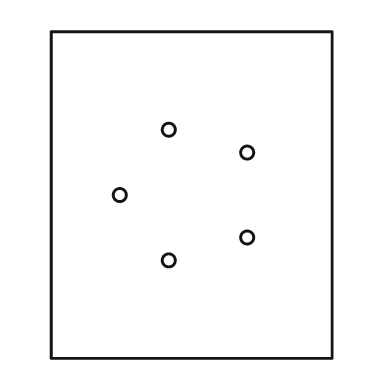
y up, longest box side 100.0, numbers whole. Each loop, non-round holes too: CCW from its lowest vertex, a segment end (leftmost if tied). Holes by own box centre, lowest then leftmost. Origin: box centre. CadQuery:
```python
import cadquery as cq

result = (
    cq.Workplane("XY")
    .moveTo(-43.0, -50.0)
    .lineTo(43.0, -50.0)
    .lineTo(43.0, 50.0)
    .lineTo(-43.0, 50.0)
    .close()
    .moveTo(-7.0, -20.0)
    .circle(2.0)
    .moveTo(17.0, -13.0)
    .circle(2.0)
    .moveTo(-22.0, 0.0)
    .circle(2.0)
    .moveTo(17.0, 13.0)
    .circle(2.0)
    .moveTo(-7.0, 20.0)
    .circle(2.0)
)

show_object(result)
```